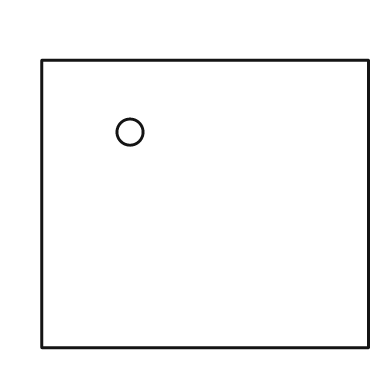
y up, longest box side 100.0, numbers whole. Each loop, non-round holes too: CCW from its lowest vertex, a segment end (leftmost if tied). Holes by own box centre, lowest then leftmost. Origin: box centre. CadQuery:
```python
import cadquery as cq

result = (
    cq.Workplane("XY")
    .moveTo(-50.0, -44.0)
    .lineTo(50.0, -44.0)
    .lineTo(50.0, 44.0)
    .lineTo(-50.0, 44.0)
    .close()
    .moveTo(-23.0, 22.0)
    .circle(4.0)
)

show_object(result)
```